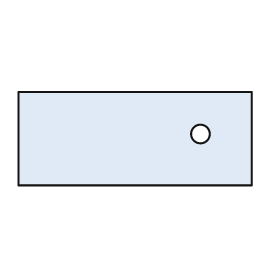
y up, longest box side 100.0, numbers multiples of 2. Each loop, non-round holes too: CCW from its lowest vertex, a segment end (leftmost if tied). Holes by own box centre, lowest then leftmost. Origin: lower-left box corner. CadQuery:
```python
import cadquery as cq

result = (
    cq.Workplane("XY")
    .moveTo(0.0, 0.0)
    .lineTo(100.0, 0.0)
    .lineTo(100.0, 40.0)
    .lineTo(0.0, 40.0)
    .close()
    .moveTo(78.0, 22.0)
    .circle(4.0)
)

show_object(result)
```